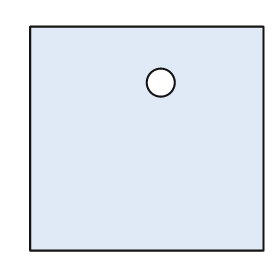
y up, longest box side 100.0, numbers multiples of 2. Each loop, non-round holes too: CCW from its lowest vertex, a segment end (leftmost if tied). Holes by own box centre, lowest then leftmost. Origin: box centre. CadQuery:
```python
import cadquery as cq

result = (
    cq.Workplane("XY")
    .moveTo(-50.0, -48.0)
    .lineTo(50.0, -48.0)
    .lineTo(50.0, 48.0)
    .lineTo(-50.0, 48.0)
    .close()
    .moveTo(6.0, 24.0)
    .circle(6.0)
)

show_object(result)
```